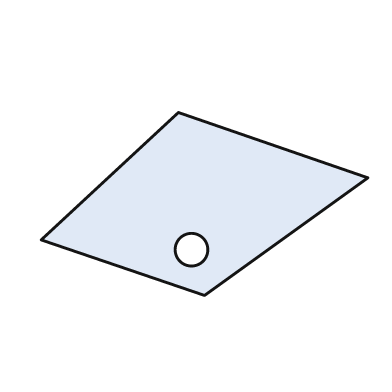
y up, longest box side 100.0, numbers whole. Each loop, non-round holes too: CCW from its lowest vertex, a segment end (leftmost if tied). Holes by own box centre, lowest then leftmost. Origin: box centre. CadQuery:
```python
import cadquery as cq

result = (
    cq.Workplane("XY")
    .moveTo(0.0, -28.0)
    .lineTo(50.0, 8.0)
    .lineTo(-8.0, 28.0)
    .lineTo(-50.0, -11.0)
    .close()
    .moveTo(-4.0, -14.0)
    .circle(5.0)
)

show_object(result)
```